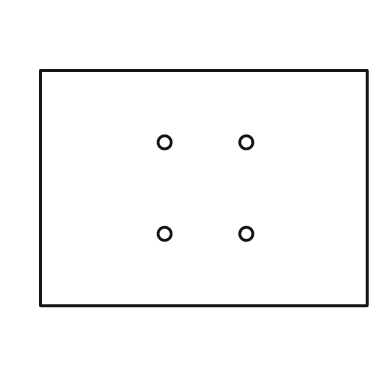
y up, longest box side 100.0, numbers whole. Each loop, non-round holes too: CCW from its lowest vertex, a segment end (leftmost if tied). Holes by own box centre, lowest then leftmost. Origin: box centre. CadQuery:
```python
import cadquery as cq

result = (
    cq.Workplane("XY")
    .moveTo(-50.0, -36.0)
    .lineTo(50.0, -36.0)
    .lineTo(50.0, 36.0)
    .lineTo(-50.0, 36.0)
    .close()
    .moveTo(-12.0, -14.0)
    .circle(2.0)
    .moveTo(13.0, -14.0)
    .circle(2.0)
    .moveTo(-12.0, 14.0)
    .circle(2.0)
    .moveTo(13.0, 14.0)
    .circle(2.0)
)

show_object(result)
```